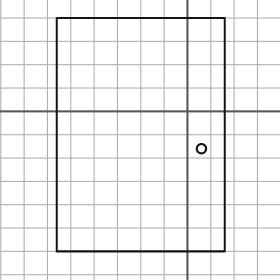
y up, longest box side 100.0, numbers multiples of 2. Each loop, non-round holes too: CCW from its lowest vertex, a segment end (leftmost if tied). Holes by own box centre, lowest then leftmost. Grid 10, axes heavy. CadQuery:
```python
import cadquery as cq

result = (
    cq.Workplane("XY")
    .moveTo(-56.0, -60.0)
    .lineTo(16.0, -60.0)
    .lineTo(16.0, 40.0)
    .lineTo(-56.0, 40.0)
    .close()
    .moveTo(6.0, -16.0)
    .circle(2.0)
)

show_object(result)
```